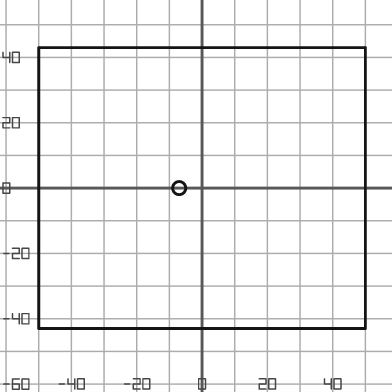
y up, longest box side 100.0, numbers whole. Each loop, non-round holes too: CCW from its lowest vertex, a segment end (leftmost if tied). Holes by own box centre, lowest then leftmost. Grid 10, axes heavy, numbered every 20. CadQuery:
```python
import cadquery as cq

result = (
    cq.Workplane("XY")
    .moveTo(-50.0, -43.0)
    .lineTo(50.0, -43.0)
    .lineTo(50.0, 43.0)
    .lineTo(-50.0, 43.0)
    .close()
    .moveTo(-7.0, 0.0)
    .circle(2.0)
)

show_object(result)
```